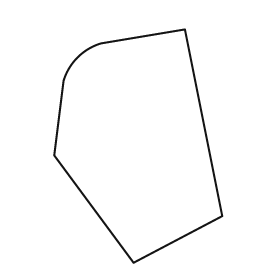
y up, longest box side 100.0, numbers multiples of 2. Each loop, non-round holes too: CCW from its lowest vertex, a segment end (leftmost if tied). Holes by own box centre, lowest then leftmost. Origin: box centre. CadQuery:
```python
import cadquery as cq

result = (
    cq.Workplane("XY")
    .moveTo(-2.0, -50.0)
    .lineTo(36.0, -30.0)
    .lineTo(20.0, 50.0)
    .lineTo(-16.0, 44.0)
    .threePointArc((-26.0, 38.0), (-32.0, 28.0))
    .lineTo(-36.0, -4.0)
    .close()
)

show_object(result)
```